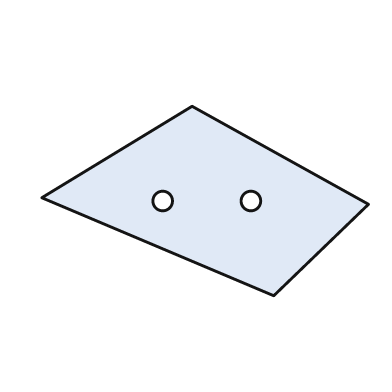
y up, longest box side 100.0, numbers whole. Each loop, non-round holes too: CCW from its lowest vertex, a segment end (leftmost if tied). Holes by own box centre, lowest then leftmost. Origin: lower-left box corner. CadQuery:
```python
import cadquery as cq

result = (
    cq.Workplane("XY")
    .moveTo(71.0, 0.0)
    .lineTo(100.0, 28.0)
    .lineTo(46.0, 58.0)
    .lineTo(0.0, 30.0)
    .close()
    .moveTo(37.0, 29.0)
    .circle(3.0)
    .moveTo(64.0, 29.0)
    .circle(3.0)
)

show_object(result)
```